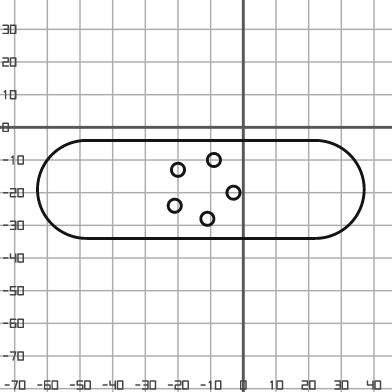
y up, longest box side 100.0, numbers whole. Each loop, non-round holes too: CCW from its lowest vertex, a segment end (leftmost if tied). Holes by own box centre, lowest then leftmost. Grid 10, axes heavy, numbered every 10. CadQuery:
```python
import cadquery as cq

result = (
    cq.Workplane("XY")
    .moveTo(-48.0, -34.0)
    .lineTo(22.0, -34.0)
    .threePointArc((37.0, -19.0), (22.0, -4.0))
    .lineTo(-48.0, -4.0)
    .threePointArc((-63.0, -19.0), (-48.0, -34.0))
    .close()
    .moveTo(-11.0, -28.0)
    .circle(2.0)
    .moveTo(-21.0, -24.0)
    .circle(2.0)
    .moveTo(-3.0, -20.0)
    .circle(2.0)
    .moveTo(-20.0, -13.0)
    .circle(2.0)
    .moveTo(-9.0, -10.0)
    .circle(2.0)
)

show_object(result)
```